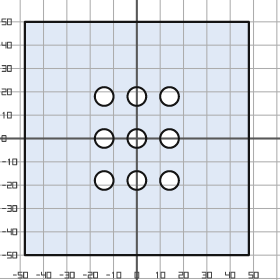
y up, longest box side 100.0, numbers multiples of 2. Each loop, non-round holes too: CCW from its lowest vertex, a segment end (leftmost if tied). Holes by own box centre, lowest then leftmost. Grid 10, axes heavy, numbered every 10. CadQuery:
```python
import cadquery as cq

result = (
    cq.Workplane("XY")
    .moveTo(-48.0, -50.0)
    .lineTo(48.0, -50.0)
    .lineTo(48.0, 50.0)
    .lineTo(-48.0, 50.0)
    .close()
    .moveTo(-14.0, -18.0)
    .circle(4.0)
    .moveTo(0.0, -18.0)
    .circle(4.0)
    .moveTo(14.0, -18.0)
    .circle(4.0)
    .moveTo(-14.0, 0.0)
    .circle(4.0)
    .moveTo(0.0, 0.0)
    .circle(4.0)
    .moveTo(14.0, 0.0)
    .circle(4.0)
    .moveTo(-14.0, 18.0)
    .circle(4.0)
    .moveTo(0.0, 18.0)
    .circle(4.0)
    .moveTo(14.0, 18.0)
    .circle(4.0)
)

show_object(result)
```